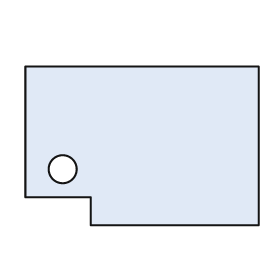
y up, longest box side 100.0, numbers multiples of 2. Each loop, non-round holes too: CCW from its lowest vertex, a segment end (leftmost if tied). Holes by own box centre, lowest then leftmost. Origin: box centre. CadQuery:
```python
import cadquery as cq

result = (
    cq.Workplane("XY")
    .moveTo(-22.0, -34.0)
    .lineTo(50.0, -34.0)
    .lineTo(50.0, 34.0)
    .lineTo(-50.0, 34.0)
    .lineTo(-50.0, -22.0)
    .lineTo(-22.0, -22.0)
    .close()
    .moveTo(-34.0, -10.0)
    .circle(6.0)
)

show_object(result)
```